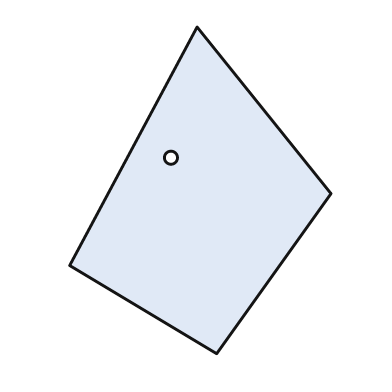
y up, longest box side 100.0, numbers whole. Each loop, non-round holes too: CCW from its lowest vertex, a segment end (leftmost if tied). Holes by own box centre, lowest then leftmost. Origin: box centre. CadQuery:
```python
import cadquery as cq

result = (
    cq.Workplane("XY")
    .moveTo(5.0, -50.0)
    .lineTo(40.0, -1.0)
    .lineTo(-1.0, 50.0)
    .lineTo(-40.0, -23.0)
    .close()
    .moveTo(-9.0, 10.0)
    .circle(2.0)
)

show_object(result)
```